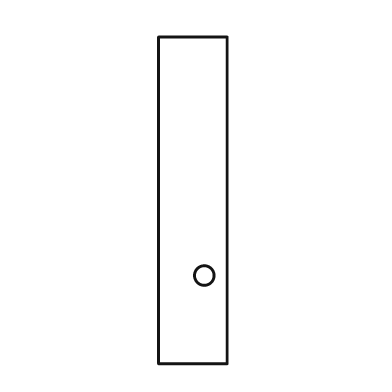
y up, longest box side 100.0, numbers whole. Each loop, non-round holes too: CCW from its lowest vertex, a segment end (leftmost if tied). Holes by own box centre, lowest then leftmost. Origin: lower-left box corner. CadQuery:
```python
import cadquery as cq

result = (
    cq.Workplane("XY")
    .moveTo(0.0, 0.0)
    .lineTo(21.0, 0.0)
    .lineTo(21.0, 100.0)
    .lineTo(0.0, 100.0)
    .close()
    .moveTo(14.0, 27.0)
    .circle(3.0)
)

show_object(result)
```